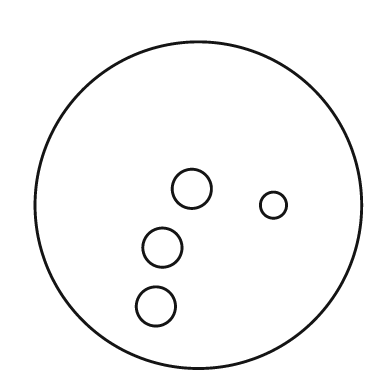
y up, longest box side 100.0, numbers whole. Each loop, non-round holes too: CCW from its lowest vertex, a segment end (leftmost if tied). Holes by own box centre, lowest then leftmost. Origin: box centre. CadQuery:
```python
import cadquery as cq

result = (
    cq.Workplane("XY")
    .moveTo(0.0, 0.0)
    .circle(50.0)
    .moveTo(-13.0, -31.0)
    .circle(6.0)
    .moveTo(-11.0, -13.0)
    .circle(6.0)
    .moveTo(23.0, 0.0)
    .circle(4.0)
    .moveTo(-2.0, 5.0)
    .circle(6.0)
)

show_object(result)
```